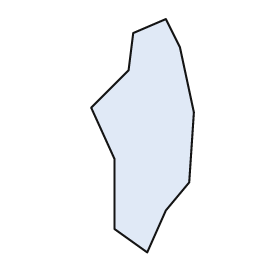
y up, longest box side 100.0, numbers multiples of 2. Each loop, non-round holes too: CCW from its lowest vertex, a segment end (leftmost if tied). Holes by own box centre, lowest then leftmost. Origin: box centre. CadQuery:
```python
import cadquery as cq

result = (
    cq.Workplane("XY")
    .moveTo(2.0, -50.0)
    .lineTo(10.0, -32.0)
    .lineTo(20.0, -20.0)
    .lineTo(22.0, 10.0)
    .lineTo(16.0, 38.0)
    .lineTo(10.0, 50.0)
    .lineTo(-4.0, 44.0)
    .lineTo(-6.0, 28.0)
    .lineTo(-22.0, 12.0)
    .lineTo(-12.0, -10.0)
    .lineTo(-12.0, -40.0)
    .close()
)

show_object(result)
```